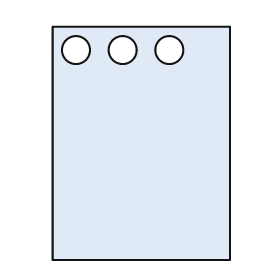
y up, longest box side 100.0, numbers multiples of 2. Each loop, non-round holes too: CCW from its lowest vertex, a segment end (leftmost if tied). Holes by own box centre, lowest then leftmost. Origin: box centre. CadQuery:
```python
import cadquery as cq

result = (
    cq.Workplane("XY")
    .moveTo(-38.0, -50.0)
    .lineTo(38.0, -50.0)
    .lineTo(38.0, 50.0)
    .lineTo(-38.0, 50.0)
    .close()
    .moveTo(-28.0, 40.0)
    .circle(6.0)
    .moveTo(-8.0, 40.0)
    .circle(6.0)
    .moveTo(12.0, 40.0)
    .circle(6.0)
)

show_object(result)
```